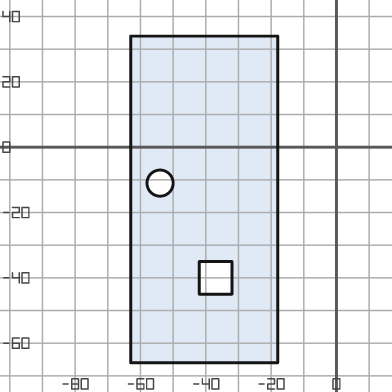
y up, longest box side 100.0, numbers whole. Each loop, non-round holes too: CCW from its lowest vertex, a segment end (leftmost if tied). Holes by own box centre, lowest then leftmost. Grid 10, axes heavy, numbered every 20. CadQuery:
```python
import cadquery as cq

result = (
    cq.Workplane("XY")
    .moveTo(-63.0, -66.0)
    .lineTo(-18.0, -66.0)
    .lineTo(-18.0, 34.0)
    .lineTo(-63.0, 34.0)
    .close()
    .moveTo(-42.0, -45.0)
    .lineTo(-32.0, -45.0)
    .lineTo(-32.0, -35.0)
    .lineTo(-42.0, -35.0)
    .close()
    .moveTo(-54.0, -11.0)
    .circle(4.0)
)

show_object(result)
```